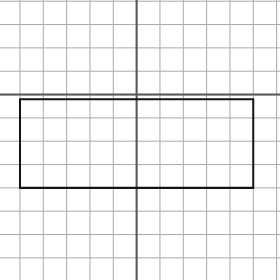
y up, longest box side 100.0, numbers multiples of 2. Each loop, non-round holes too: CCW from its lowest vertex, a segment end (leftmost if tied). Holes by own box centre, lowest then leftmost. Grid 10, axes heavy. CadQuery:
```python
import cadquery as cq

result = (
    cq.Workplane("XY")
    .moveTo(-50.0, -40.0)
    .lineTo(50.0, -40.0)
    .lineTo(50.0, -2.0)
    .lineTo(-50.0, -2.0)
    .close()
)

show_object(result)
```